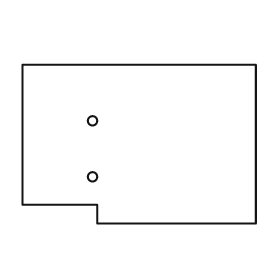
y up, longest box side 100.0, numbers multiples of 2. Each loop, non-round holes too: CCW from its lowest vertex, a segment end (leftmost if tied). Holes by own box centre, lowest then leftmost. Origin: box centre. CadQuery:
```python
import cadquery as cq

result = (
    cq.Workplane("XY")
    .moveTo(-18.0, -34.0)
    .lineTo(50.0, -34.0)
    .lineTo(50.0, 34.0)
    .lineTo(-50.0, 34.0)
    .lineTo(-50.0, -26.0)
    .lineTo(-18.0, -26.0)
    .close()
    .moveTo(-20.0, -14.0)
    .circle(2.0)
    .moveTo(-20.0, 10.0)
    .circle(2.0)
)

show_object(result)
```